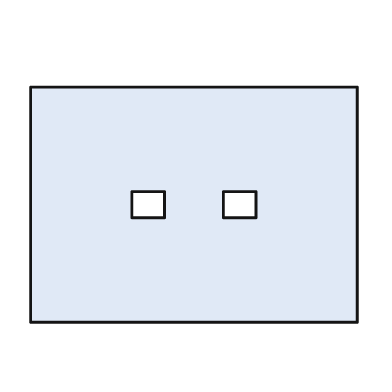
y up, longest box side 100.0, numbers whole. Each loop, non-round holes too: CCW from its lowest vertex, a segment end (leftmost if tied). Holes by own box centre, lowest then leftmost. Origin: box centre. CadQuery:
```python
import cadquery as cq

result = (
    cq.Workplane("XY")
    .moveTo(-50.0, -36.0)
    .lineTo(50.0, -36.0)
    .lineTo(50.0, 36.0)
    .lineTo(-50.0, 36.0)
    .close()
    .moveTo(-19.0, -4.0)
    .lineTo(-9.0, -4.0)
    .lineTo(-9.0, 4.0)
    .lineTo(-19.0, 4.0)
    .close()
    .moveTo(9.0, -4.0)
    .lineTo(19.0, -4.0)
    .lineTo(19.0, 4.0)
    .lineTo(9.0, 4.0)
    .close()
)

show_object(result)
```